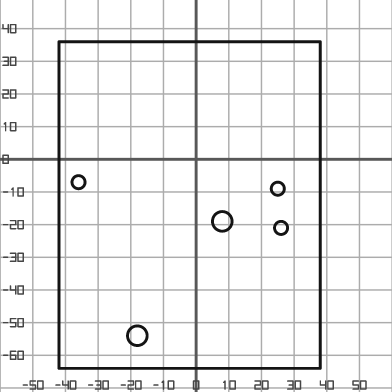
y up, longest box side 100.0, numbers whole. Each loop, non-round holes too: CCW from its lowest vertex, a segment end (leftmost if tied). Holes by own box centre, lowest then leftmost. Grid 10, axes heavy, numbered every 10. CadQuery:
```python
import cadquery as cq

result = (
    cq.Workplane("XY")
    .moveTo(-42.0, -64.0)
    .lineTo(38.0, -64.0)
    .lineTo(38.0, 36.0)
    .lineTo(-42.0, 36.0)
    .close()
    .moveTo(-18.0, -54.0)
    .circle(3.0)
    .moveTo(26.0, -21.0)
    .circle(2.0)
    .moveTo(8.0, -19.0)
    .circle(3.0)
    .moveTo(25.0, -9.0)
    .circle(2.0)
    .moveTo(-36.0, -7.0)
    .circle(2.0)
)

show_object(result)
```